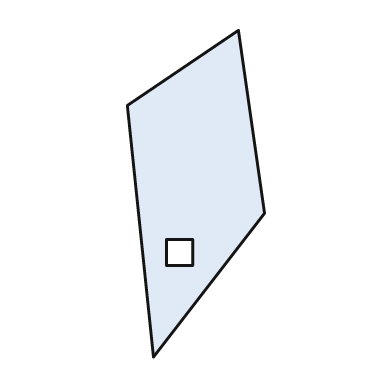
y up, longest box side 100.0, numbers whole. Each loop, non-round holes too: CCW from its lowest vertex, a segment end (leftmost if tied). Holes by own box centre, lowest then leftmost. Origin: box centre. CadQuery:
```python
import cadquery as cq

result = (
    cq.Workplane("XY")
    .moveTo(-13.0, -50.0)
    .lineTo(21.0, -6.0)
    .lineTo(13.0, 50.0)
    .lineTo(-21.0, 27.0)
    .close()
    .moveTo(-9.0, -22.0)
    .lineTo(-1.0, -22.0)
    .lineTo(-1.0, -14.0)
    .lineTo(-9.0, -14.0)
    .close()
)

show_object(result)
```